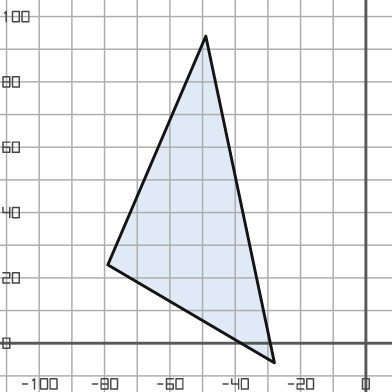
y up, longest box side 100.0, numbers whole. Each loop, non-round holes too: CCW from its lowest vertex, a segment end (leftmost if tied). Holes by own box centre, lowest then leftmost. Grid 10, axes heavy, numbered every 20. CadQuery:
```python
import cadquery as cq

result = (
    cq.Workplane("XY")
    .moveTo(-28.0, -6.0)
    .lineTo(-49.0, 94.0)
    .lineTo(-79.0, 24.0)
    .close()
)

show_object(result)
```